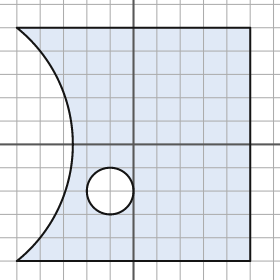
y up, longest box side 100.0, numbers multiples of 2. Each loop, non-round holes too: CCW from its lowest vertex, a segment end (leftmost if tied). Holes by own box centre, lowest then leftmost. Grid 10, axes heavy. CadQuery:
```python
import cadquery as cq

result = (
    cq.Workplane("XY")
    .moveTo(-50.0, -50.0)
    .lineTo(50.0, -50.0)
    .lineTo(50.0, 50.0)
    .lineTo(-50.0, 50.0)
    .threePointArc((-26.0, 0.0), (-50.0, -50.0))
    .close()
    .moveTo(-10.0, -20.0)
    .circle(10.0)
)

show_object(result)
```